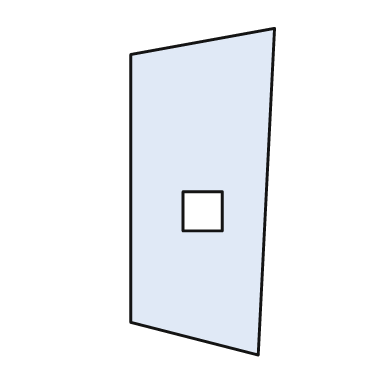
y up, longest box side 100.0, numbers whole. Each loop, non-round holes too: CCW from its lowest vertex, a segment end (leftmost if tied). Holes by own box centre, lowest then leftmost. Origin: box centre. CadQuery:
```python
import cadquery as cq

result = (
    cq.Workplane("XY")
    .moveTo(17.0, -50.0)
    .lineTo(22.0, 50.0)
    .lineTo(-22.0, 42.0)
    .lineTo(-22.0, -40.0)
    .close()
    .moveTo(-6.0, -12.0)
    .lineTo(6.0, -12.0)
    .lineTo(6.0, 0.0)
    .lineTo(-6.0, 0.0)
    .close()
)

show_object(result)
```